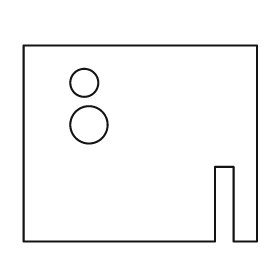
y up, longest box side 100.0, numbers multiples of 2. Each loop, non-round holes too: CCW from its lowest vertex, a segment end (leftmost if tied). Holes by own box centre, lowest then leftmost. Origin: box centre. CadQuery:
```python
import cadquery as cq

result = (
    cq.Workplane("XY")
    .moveTo(-50.0, -42.0)
    .lineTo(32.0, -42.0)
    .lineTo(32.0, -10.0)
    .lineTo(40.0, -10.0)
    .lineTo(40.0, -42.0)
    .lineTo(50.0, -42.0)
    .lineTo(50.0, 42.0)
    .lineTo(-50.0, 42.0)
    .close()
    .moveTo(-22.0, 8.0)
    .circle(8.0)
    .moveTo(-24.0, 26.0)
    .circle(6.0)
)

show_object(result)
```